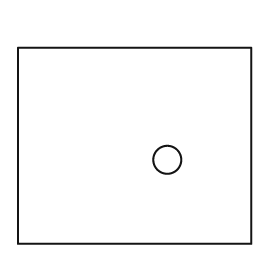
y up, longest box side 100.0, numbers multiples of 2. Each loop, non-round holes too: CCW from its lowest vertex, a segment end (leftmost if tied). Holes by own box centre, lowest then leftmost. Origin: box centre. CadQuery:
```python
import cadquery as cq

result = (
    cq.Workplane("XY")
    .moveTo(-50.0, -42.0)
    .lineTo(50.0, -42.0)
    .lineTo(50.0, 42.0)
    .lineTo(-50.0, 42.0)
    .close()
    .moveTo(14.0, -6.0)
    .circle(6.0)
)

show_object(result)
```